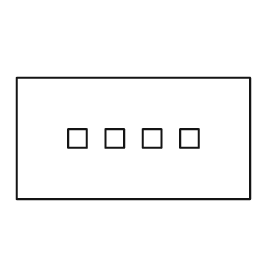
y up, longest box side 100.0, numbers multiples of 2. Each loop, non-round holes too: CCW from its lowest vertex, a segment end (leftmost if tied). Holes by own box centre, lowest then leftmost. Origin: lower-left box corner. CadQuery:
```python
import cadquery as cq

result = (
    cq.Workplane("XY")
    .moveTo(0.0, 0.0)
    .lineTo(100.0, 0.0)
    .lineTo(100.0, 52.0)
    .lineTo(0.0, 52.0)
    .close()
    .moveTo(22.0, 22.0)
    .lineTo(30.0, 22.0)
    .lineTo(30.0, 30.0)
    .lineTo(22.0, 30.0)
    .close()
    .moveTo(38.0, 22.0)
    .lineTo(46.0, 22.0)
    .lineTo(46.0, 30.0)
    .lineTo(38.0, 30.0)
    .close()
    .moveTo(54.0, 22.0)
    .lineTo(62.0, 22.0)
    .lineTo(62.0, 30.0)
    .lineTo(54.0, 30.0)
    .close()
    .moveTo(70.0, 22.0)
    .lineTo(78.0, 22.0)
    .lineTo(78.0, 30.0)
    .lineTo(70.0, 30.0)
    .close()
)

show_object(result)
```